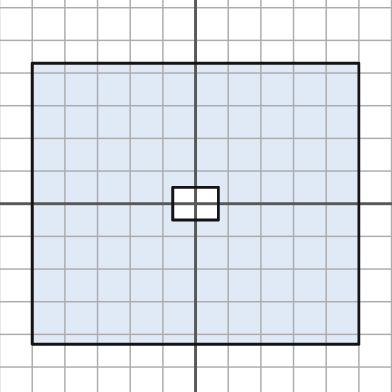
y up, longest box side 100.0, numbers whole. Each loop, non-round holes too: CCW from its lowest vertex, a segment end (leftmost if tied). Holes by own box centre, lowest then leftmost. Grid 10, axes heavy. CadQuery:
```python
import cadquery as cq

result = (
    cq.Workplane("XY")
    .moveTo(-50.0, -43.0)
    .lineTo(50.0, -43.0)
    .lineTo(50.0, 43.0)
    .lineTo(-50.0, 43.0)
    .close()
    .moveTo(-7.0, -5.0)
    .lineTo(7.0, -5.0)
    .lineTo(7.0, 5.0)
    .lineTo(-7.0, 5.0)
    .close()
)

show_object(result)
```